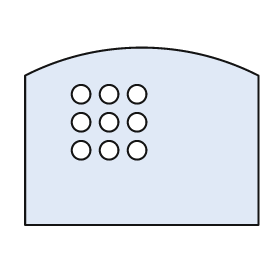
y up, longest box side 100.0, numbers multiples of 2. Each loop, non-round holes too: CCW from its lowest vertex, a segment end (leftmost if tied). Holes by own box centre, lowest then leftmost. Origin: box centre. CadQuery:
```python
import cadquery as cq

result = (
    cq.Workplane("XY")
    .moveTo(-50.0, -38.0)
    .lineTo(50.0, -38.0)
    .lineTo(50.0, 26.0)
    .threePointArc((0.0, 38.0), (-50.0, 26.0))
    .close()
    .moveTo(-26.0, -6.0)
    .circle(4.0)
    .moveTo(-14.0, -6.0)
    .circle(4.0)
    .moveTo(-2.0, -6.0)
    .circle(4.0)
    .moveTo(-26.0, 6.0)
    .circle(4.0)
    .moveTo(-14.0, 6.0)
    .circle(4.0)
    .moveTo(-2.0, 6.0)
    .circle(4.0)
    .moveTo(-26.0, 18.0)
    .circle(4.0)
    .moveTo(-14.0, 18.0)
    .circle(4.0)
    .moveTo(-2.0, 18.0)
    .circle(4.0)
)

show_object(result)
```